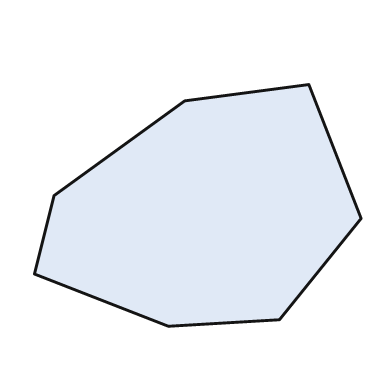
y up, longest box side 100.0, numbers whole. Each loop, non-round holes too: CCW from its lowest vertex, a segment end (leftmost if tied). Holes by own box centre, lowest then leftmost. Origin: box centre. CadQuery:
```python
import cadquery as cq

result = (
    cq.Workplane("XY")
    .moveTo(-9.0, -37.0)
    .lineTo(25.0, -35.0)
    .lineTo(50.0, -4.0)
    .lineTo(34.0, 37.0)
    .lineTo(-4.0, 32.0)
    .lineTo(-44.0, 3.0)
    .lineTo(-50.0, -21.0)
    .close()
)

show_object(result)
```